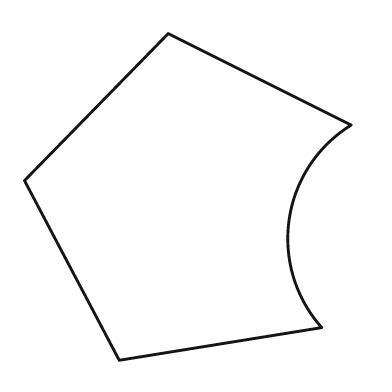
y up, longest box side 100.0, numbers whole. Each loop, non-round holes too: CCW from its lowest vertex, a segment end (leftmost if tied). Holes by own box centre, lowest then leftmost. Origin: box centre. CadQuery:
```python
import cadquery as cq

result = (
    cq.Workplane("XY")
    .moveTo(-21.0, -50.0)
    .lineTo(41.0, -40.0)
    .threePointArc((31.0, -7.0), (50.0, 22.0))
    .lineTo(-6.0, 50.0)
    .lineTo(-50.0, 5.0)
    .close()
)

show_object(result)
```